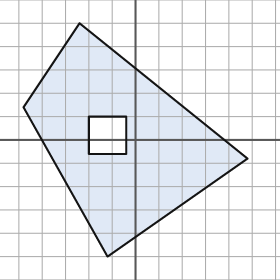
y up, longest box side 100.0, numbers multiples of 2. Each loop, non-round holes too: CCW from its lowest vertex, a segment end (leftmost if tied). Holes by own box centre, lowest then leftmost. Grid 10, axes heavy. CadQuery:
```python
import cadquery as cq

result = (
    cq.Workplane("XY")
    .moveTo(-12.0, -50.0)
    .lineTo(48.0, -8.0)
    .lineTo(-24.0, 50.0)
    .lineTo(-48.0, 14.0)
    .close()
    .moveTo(-20.0, -6.0)
    .lineTo(-4.0, -6.0)
    .lineTo(-4.0, 10.0)
    .lineTo(-20.0, 10.0)
    .close()
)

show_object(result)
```